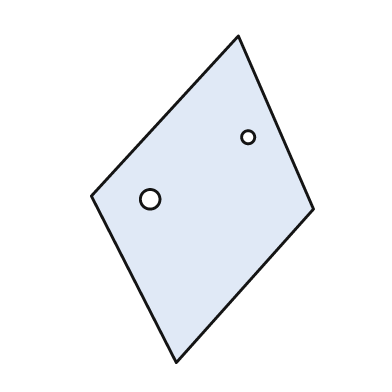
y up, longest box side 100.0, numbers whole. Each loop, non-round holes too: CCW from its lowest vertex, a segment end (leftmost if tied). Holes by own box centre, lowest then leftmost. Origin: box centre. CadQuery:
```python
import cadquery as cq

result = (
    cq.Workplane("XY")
    .moveTo(-8.0, -50.0)
    .lineTo(34.0, -3.0)
    .lineTo(11.0, 50.0)
    .lineTo(-34.0, 1.0)
    .close()
    .moveTo(-16.0, 0.0)
    .circle(3.0)
    .moveTo(14.0, 19.0)
    .circle(2.0)
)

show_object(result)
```